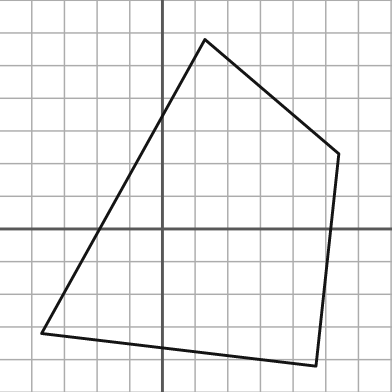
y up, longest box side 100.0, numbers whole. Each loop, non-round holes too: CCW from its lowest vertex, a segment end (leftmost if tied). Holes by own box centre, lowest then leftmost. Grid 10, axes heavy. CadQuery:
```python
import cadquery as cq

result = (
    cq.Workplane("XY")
    .moveTo(47.0, -42.0)
    .lineTo(54.0, 23.0)
    .lineTo(13.0, 58.0)
    .lineTo(-37.0, -32.0)
    .close()
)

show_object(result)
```